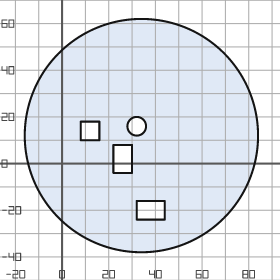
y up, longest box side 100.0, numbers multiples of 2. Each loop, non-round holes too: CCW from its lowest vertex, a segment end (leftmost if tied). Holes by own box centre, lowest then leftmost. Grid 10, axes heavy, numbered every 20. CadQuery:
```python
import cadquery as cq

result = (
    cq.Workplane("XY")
    .moveTo(34.0, 12.0)
    .circle(50.0)
    .moveTo(32.0, -24.0)
    .lineTo(44.0, -24.0)
    .lineTo(44.0, -16.0)
    .lineTo(32.0, -16.0)
    .close()
    .moveTo(22.0, -4.0)
    .lineTo(30.0, -4.0)
    .lineTo(30.0, 8.0)
    .lineTo(22.0, 8.0)
    .close()
    .moveTo(8.0, 10.0)
    .lineTo(16.0, 10.0)
    .lineTo(16.0, 18.0)
    .lineTo(8.0, 18.0)
    .close()
    .moveTo(32.0, 16.0)
    .circle(4.0)
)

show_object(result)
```